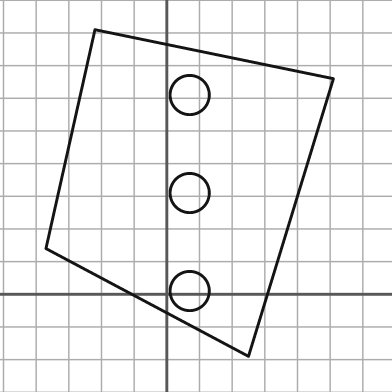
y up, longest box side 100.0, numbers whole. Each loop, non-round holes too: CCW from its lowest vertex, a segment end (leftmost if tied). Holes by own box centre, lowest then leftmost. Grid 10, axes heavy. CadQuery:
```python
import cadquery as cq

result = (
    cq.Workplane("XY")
    .moveTo(25.0, -19.0)
    .lineTo(51.0, 66.0)
    .lineTo(-22.0, 81.0)
    .lineTo(-37.0, 14.0)
    .close()
    .moveTo(7.0, 1.0)
    .circle(6.0)
    .moveTo(7.0, 31.0)
    .circle(6.0)
    .moveTo(7.0, 61.0)
    .circle(6.0)
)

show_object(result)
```